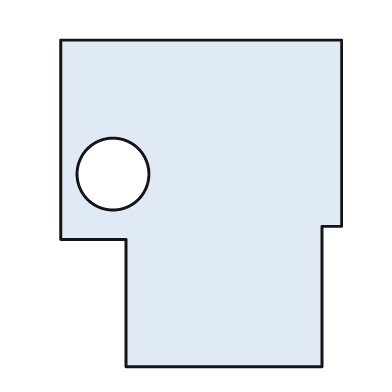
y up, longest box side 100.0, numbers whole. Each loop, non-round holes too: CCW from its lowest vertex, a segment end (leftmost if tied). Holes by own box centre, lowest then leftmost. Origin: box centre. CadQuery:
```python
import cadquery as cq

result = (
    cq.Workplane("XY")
    .moveTo(-23.0, -50.0)
    .lineTo(37.0, -50.0)
    .lineTo(37.0, -7.0)
    .lineTo(43.0, -7.0)
    .lineTo(43.0, 50.0)
    .lineTo(-43.0, 50.0)
    .lineTo(-43.0, -11.0)
    .lineTo(-23.0, -11.0)
    .close()
    .moveTo(-27.0, 9.0)
    .circle(11.0)
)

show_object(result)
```